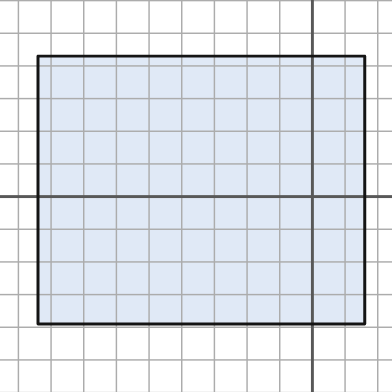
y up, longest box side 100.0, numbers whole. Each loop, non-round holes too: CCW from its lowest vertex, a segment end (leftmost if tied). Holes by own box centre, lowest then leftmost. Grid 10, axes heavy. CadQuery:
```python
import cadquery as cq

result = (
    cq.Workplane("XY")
    .moveTo(-84.0, -39.0)
    .lineTo(16.0, -39.0)
    .lineTo(16.0, 43.0)
    .lineTo(-84.0, 43.0)
    .close()
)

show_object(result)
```